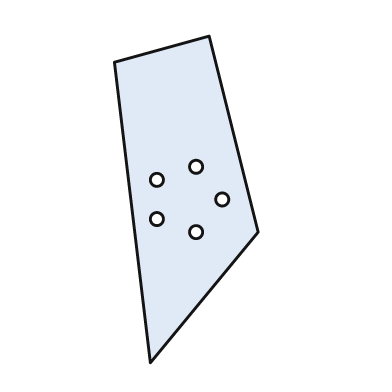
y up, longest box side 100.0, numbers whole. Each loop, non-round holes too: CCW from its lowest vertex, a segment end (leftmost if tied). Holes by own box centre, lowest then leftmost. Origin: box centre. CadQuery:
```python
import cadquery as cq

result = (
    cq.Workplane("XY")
    .moveTo(-11.0, -50.0)
    .lineTo(22.0, -10.0)
    .lineTo(7.0, 50.0)
    .lineTo(-22.0, 42.0)
    .close()
    .moveTo(3.0, -10.0)
    .circle(2.0)
    .moveTo(-9.0, -6.0)
    .circle(2.0)
    .moveTo(11.0, 0.0)
    .circle(2.0)
    .moveTo(-9.0, 6.0)
    .circle(2.0)
    .moveTo(3.0, 10.0)
    .circle(2.0)
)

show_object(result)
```